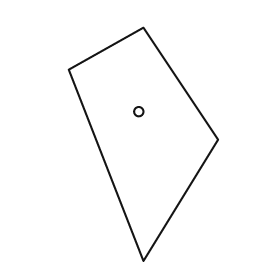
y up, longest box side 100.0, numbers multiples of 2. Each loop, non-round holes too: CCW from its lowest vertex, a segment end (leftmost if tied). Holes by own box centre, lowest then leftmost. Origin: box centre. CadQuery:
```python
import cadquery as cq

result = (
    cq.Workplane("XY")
    .moveTo(0.0, -50.0)
    .lineTo(32.0, 2.0)
    .lineTo(0.0, 50.0)
    .lineTo(-32.0, 32.0)
    .close()
    .moveTo(-2.0, 14.0)
    .circle(2.0)
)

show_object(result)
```